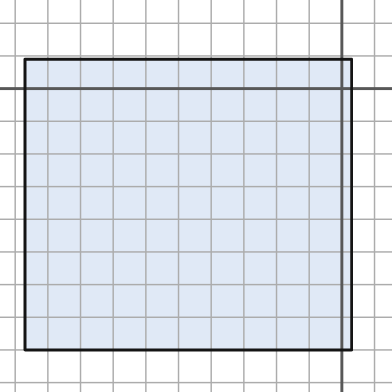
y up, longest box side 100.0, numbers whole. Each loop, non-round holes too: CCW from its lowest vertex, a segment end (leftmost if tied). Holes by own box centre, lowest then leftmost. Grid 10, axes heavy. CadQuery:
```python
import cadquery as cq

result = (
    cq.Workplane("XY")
    .moveTo(-97.0, -80.0)
    .lineTo(3.0, -80.0)
    .lineTo(3.0, 9.0)
    .lineTo(-97.0, 9.0)
    .close()
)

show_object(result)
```